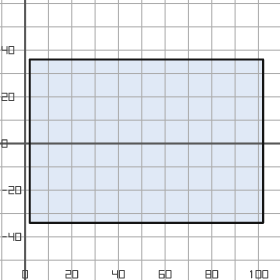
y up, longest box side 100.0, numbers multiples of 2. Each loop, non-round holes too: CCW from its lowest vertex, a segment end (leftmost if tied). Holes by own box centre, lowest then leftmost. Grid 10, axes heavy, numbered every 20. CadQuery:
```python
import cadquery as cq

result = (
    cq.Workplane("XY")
    .moveTo(2.0, -34.0)
    .lineTo(102.0, -34.0)
    .lineTo(102.0, 36.0)
    .lineTo(2.0, 36.0)
    .close()
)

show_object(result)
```